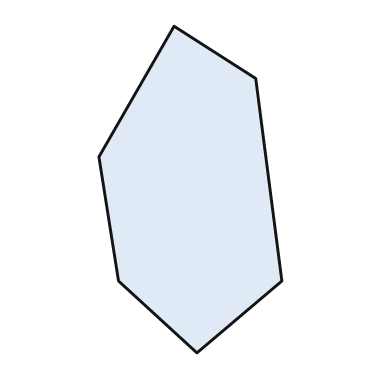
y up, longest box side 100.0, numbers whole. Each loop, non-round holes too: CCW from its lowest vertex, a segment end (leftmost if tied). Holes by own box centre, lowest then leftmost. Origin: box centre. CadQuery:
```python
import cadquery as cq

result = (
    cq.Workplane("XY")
    .moveTo(2.0, -50.0)
    .lineTo(28.0, -28.0)
    .lineTo(20.0, 34.0)
    .lineTo(-5.0, 50.0)
    .lineTo(-28.0, 10.0)
    .lineTo(-22.0, -28.0)
    .close()
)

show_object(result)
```